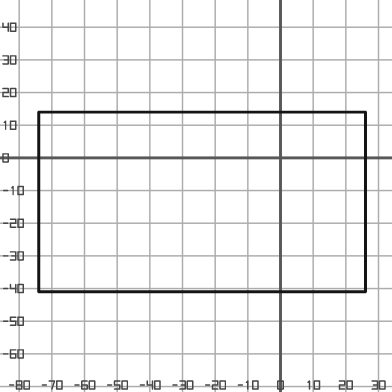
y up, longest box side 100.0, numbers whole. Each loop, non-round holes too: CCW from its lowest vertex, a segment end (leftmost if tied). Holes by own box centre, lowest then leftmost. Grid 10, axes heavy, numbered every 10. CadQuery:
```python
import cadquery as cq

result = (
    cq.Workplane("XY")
    .moveTo(-74.0, -41.0)
    .lineTo(26.0, -41.0)
    .lineTo(26.0, 14.0)
    .lineTo(-74.0, 14.0)
    .close()
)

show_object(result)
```